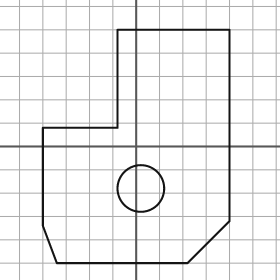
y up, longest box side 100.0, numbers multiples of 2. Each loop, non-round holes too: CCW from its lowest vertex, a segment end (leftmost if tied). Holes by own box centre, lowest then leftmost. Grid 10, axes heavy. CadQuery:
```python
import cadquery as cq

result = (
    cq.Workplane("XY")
    .moveTo(-34.0, -50.0)
    .lineTo(22.0, -50.0)
    .lineTo(40.0, -32.0)
    .lineTo(40.0, 50.0)
    .lineTo(-8.0, 50.0)
    .lineTo(-8.0, 8.0)
    .lineTo(-40.0, 8.0)
    .lineTo(-40.0, -34.0)
    .close()
    .moveTo(2.0, -18.0)
    .circle(10.0)
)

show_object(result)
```